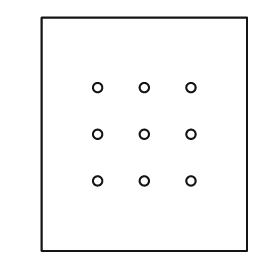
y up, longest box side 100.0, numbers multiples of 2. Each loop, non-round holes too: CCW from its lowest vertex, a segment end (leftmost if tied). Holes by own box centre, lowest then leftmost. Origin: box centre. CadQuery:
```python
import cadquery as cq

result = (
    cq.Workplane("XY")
    .moveTo(-44.0, -50.0)
    .lineTo(44.0, -50.0)
    .lineTo(44.0, 50.0)
    .lineTo(-44.0, 50.0)
    .close()
    .moveTo(-20.0, -20.0)
    .circle(2.0)
    .moveTo(0.0, -20.0)
    .circle(2.0)
    .moveTo(20.0, -20.0)
    .circle(2.0)
    .moveTo(-20.0, 0.0)
    .circle(2.0)
    .moveTo(0.0, 0.0)
    .circle(2.0)
    .moveTo(20.0, 0.0)
    .circle(2.0)
    .moveTo(-20.0, 20.0)
    .circle(2.0)
    .moveTo(0.0, 20.0)
    .circle(2.0)
    .moveTo(20.0, 20.0)
    .circle(2.0)
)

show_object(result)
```